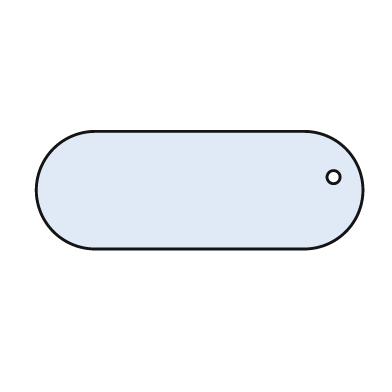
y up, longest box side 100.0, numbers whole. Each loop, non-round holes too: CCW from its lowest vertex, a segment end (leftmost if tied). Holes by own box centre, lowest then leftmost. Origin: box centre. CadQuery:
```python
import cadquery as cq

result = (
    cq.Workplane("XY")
    .moveTo(-32.0, -18.0)
    .lineTo(32.0, -18.0)
    .threePointArc((50.0, 0.0), (32.0, 18.0))
    .lineTo(-32.0, 18.0)
    .threePointArc((-50.0, 0.0), (-32.0, -18.0))
    .close()
    .moveTo(41.0, 4.0)
    .circle(2.0)
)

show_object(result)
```